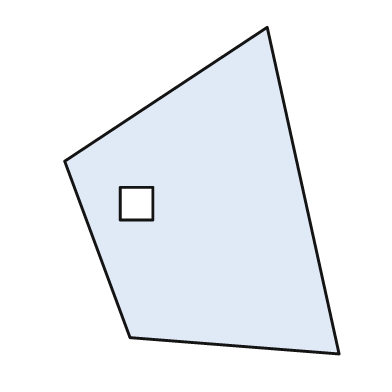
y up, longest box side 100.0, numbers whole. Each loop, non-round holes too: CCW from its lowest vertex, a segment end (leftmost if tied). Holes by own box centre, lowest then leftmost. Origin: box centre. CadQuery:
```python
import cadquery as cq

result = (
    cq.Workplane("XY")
    .moveTo(42.0, -50.0)
    .lineTo(20.0, 50.0)
    .lineTo(-42.0, 9.0)
    .lineTo(-22.0, -45.0)
    .close()
    .moveTo(-25.0, -9.0)
    .lineTo(-15.0, -9.0)
    .lineTo(-15.0, 1.0)
    .lineTo(-25.0, 1.0)
    .close()
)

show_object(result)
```